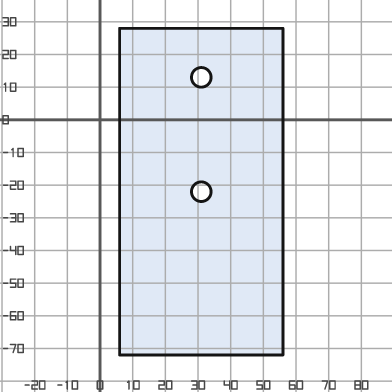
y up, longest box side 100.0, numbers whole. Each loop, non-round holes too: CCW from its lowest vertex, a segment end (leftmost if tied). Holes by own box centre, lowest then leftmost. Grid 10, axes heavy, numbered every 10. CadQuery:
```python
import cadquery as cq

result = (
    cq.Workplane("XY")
    .moveTo(6.0, -72.0)
    .lineTo(56.0, -72.0)
    .lineTo(56.0, 28.0)
    .lineTo(6.0, 28.0)
    .close()
    .moveTo(31.0, -22.0)
    .circle(3.0)
    .moveTo(31.0, 13.0)
    .circle(3.0)
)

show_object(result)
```